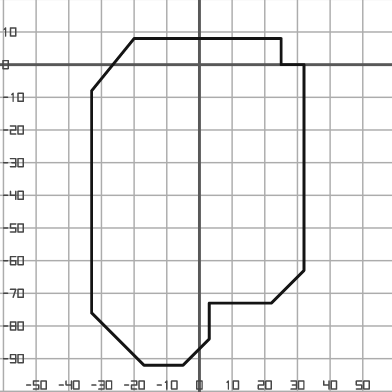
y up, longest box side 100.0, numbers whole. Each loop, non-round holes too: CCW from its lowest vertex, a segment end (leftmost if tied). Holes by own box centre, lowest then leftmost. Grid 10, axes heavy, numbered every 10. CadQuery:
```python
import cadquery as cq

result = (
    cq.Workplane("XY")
    .moveTo(-17.0, -92.0)
    .lineTo(-5.0, -92.0)
    .lineTo(3.0, -84.0)
    .lineTo(3.0, -73.0)
    .lineTo(22.0, -73.0)
    .lineTo(32.0, -63.0)
    .lineTo(32.0, 0.0)
    .lineTo(25.0, 0.0)
    .lineTo(25.0, 8.0)
    .lineTo(-20.0, 8.0)
    .lineTo(-33.0, -8.0)
    .lineTo(-33.0, -76.0)
    .close()
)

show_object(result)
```